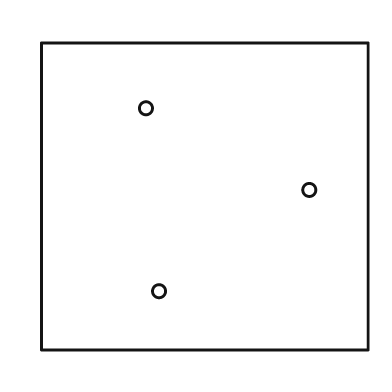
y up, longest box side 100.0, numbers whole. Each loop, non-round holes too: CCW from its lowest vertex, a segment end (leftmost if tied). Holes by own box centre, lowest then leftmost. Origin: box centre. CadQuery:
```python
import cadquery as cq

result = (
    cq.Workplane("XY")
    .moveTo(-50.0, -47.0)
    .lineTo(50.0, -47.0)
    .lineTo(50.0, 47.0)
    .lineTo(-50.0, 47.0)
    .close()
    .moveTo(-14.0, -29.0)
    .circle(2.0)
    .moveTo(32.0, 2.0)
    .circle(2.0)
    .moveTo(-18.0, 27.0)
    .circle(2.0)
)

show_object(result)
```